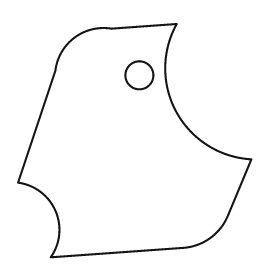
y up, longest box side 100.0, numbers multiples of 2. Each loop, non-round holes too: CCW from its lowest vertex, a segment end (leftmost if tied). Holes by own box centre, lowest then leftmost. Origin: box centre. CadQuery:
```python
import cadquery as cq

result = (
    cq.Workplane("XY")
    .moveTo(-36.0, -50.0)
    .lineTo(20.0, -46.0)
    .threePointArc((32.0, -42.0), (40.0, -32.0))
    .lineTo(50.0, -8.0)
    .threePointArc((18.0, 12.0), (18.0, 50.0))
    .lineTo(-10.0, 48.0)
    .threePointArc((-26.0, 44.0), (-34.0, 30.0))
    .lineTo(-50.0, -18.0)
    .threePointArc((-34.0, -30.0), (-36.0, -50.0))
    .close()
    .moveTo(2.0, 28.0)
    .circle(6.0)
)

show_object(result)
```